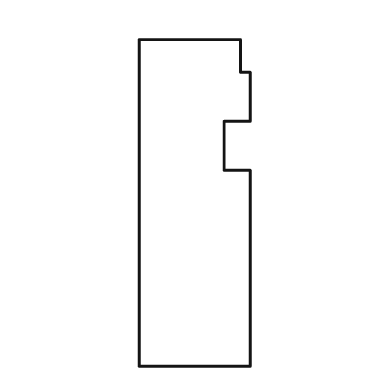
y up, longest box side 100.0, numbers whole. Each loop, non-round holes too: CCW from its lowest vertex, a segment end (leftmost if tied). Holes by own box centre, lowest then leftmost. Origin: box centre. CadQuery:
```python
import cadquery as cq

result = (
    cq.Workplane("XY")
    .moveTo(-17.0, -50.0)
    .lineTo(17.0, -50.0)
    .lineTo(17.0, 10.0)
    .lineTo(9.0, 10.0)
    .lineTo(9.0, 25.0)
    .lineTo(17.0, 25.0)
    .lineTo(17.0, 40.0)
    .lineTo(14.0, 40.0)
    .lineTo(14.0, 50.0)
    .lineTo(-17.0, 50.0)
    .close()
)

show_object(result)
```